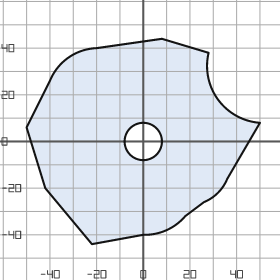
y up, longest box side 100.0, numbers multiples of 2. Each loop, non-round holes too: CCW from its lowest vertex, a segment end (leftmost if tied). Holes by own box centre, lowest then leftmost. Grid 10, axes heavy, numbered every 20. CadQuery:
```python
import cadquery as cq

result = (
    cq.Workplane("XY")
    .moveTo(-22.0, -44.0)
    .lineTo(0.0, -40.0)
    .threePointArc((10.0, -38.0), (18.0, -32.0))
    .lineTo(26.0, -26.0)
    .threePointArc((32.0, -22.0), (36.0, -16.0))
    .lineTo(50.0, 8.0)
    .threePointArc((32.0, 18.0), (28.0, 38.0))
    .lineTo(8.0, 44.0)
    .lineTo(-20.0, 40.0)
    .threePointArc((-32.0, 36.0), (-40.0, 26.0))
    .lineTo(-50.0, 6.0)
    .lineTo(-42.0, -20.0)
    .close()
    .moveTo(0.0, 0.0)
    .circle(8.0)
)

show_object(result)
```